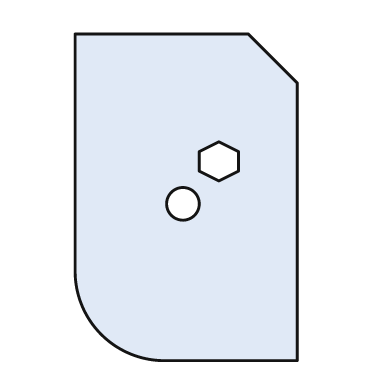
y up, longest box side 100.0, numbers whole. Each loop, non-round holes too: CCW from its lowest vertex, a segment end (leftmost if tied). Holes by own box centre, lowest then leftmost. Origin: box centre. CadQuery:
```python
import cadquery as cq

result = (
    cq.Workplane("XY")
    .moveTo(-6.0, -50.0)
    .lineTo(34.0, -50.0)
    .lineTo(34.0, 35.0)
    .lineTo(19.0, 50.0)
    .lineTo(-34.0, 50.0)
    .lineTo(-34.0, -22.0)
    .threePointArc((-26.0, -42.0), (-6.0, -50.0))
    .close()
    .moveTo(-1.0, -2.0)
    .circle(5.0)
    .moveTo(10.0, 5.0)
    .lineTo(16.0, 8.0)
    .lineTo(16.0, 14.0)
    .lineTo(10.0, 17.0)
    .lineTo(4.0, 14.0)
    .lineTo(4.0, 8.0)
    .close()
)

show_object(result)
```